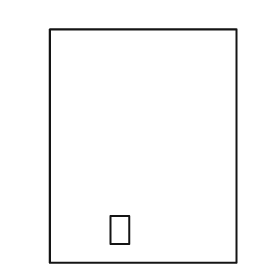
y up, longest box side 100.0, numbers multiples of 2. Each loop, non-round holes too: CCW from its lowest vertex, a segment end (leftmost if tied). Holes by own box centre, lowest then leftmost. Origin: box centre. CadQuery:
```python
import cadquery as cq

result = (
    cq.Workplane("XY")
    .moveTo(-40.0, -50.0)
    .lineTo(40.0, -50.0)
    .lineTo(40.0, 50.0)
    .lineTo(-40.0, 50.0)
    .close()
    .moveTo(-14.0, -42.0)
    .lineTo(-6.0, -42.0)
    .lineTo(-6.0, -30.0)
    .lineTo(-14.0, -30.0)
    .close()
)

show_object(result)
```